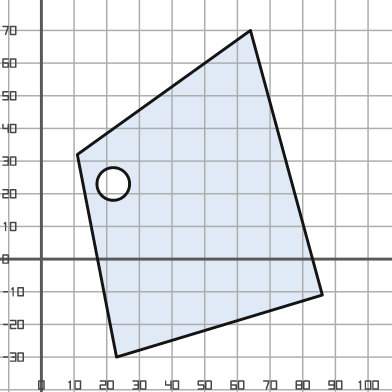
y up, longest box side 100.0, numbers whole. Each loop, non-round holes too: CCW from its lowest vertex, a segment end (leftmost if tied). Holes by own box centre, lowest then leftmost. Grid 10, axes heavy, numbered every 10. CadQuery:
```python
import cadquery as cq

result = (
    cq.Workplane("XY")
    .moveTo(23.0, -30.0)
    .lineTo(86.0, -11.0)
    .lineTo(64.0, 70.0)
    .lineTo(11.0, 32.0)
    .close()
    .moveTo(22.0, 23.0)
    .circle(5.0)
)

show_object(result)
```